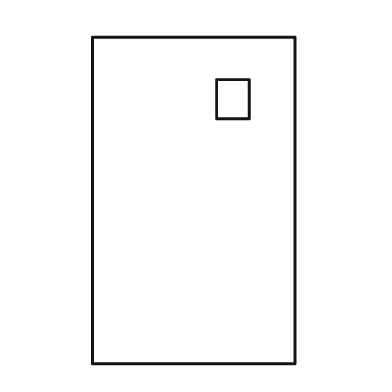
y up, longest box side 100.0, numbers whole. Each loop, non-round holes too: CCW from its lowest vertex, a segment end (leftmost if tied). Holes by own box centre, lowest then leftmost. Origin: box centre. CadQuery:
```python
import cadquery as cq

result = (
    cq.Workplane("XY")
    .moveTo(-31.0, -50.0)
    .lineTo(31.0, -50.0)
    .lineTo(31.0, 50.0)
    .lineTo(-31.0, 50.0)
    .close()
    .moveTo(7.0, 25.0)
    .lineTo(17.0, 25.0)
    .lineTo(17.0, 37.0)
    .lineTo(7.0, 37.0)
    .close()
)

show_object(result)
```